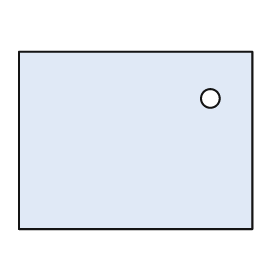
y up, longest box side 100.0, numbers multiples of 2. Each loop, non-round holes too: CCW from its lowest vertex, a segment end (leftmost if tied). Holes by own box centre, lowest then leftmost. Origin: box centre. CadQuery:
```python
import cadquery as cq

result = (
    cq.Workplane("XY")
    .moveTo(-50.0, -38.0)
    .lineTo(50.0, -38.0)
    .lineTo(50.0, 38.0)
    .lineTo(-50.0, 38.0)
    .close()
    .moveTo(32.0, 18.0)
    .circle(4.0)
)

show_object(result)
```